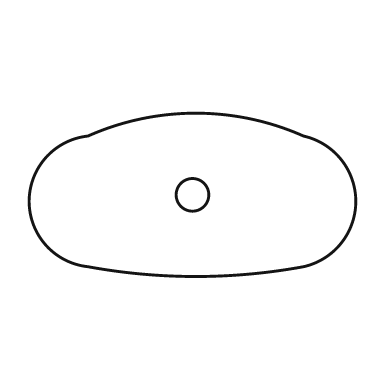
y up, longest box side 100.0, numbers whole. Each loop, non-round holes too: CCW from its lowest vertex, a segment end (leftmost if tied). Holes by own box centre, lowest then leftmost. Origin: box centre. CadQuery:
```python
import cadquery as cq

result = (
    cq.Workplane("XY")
    .moveTo(-32.0, -22.0)
    .threePointArc((1.0, -25.0), (34.0, -22.0))
    .threePointArc((50.0, -2.0), (34.0, 18.0))
    .threePointArc((1.0, 25.0), (-32.0, 18.0))
    .threePointArc((-50.0, -2.0), (-32.0, -22.0))
    .close()
    .moveTo(0.0, 0.0)
    .circle(5.0)
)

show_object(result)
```